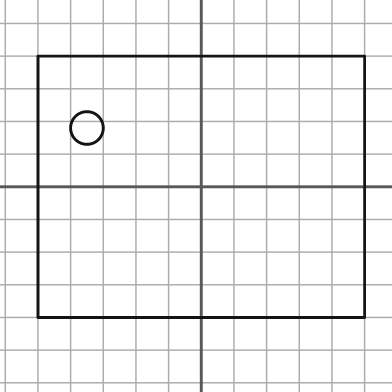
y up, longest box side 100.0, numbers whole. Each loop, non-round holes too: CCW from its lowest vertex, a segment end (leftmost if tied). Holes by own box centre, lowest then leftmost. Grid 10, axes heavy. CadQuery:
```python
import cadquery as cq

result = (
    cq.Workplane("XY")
    .moveTo(-50.0, -40.0)
    .lineTo(50.0, -40.0)
    .lineTo(50.0, 40.0)
    .lineTo(-50.0, 40.0)
    .close()
    .moveTo(-35.0, 18.0)
    .circle(5.0)
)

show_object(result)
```